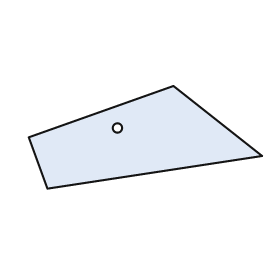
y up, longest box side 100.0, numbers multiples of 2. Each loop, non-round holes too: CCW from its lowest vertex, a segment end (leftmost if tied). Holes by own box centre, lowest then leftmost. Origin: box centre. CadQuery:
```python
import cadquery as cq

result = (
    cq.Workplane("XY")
    .moveTo(-42.0, -22.0)
    .lineTo(50.0, -8.0)
    .lineTo(12.0, 22.0)
    .lineTo(-50.0, 0.0)
    .close()
    .moveTo(-12.0, 4.0)
    .circle(2.0)
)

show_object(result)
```